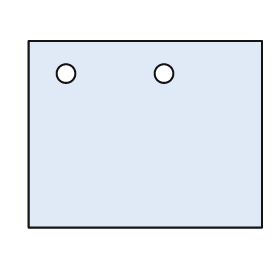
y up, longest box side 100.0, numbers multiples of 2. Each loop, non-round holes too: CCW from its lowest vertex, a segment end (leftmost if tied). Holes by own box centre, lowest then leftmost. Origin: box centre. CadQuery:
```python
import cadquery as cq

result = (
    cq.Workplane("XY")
    .moveTo(-50.0, -40.0)
    .lineTo(50.0, -40.0)
    .lineTo(50.0, 40.0)
    .lineTo(-50.0, 40.0)
    .close()
    .moveTo(-34.0, 26.0)
    .circle(4.0)
    .moveTo(8.0, 26.0)
    .circle(4.0)
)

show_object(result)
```